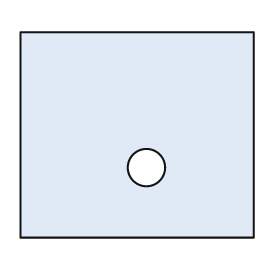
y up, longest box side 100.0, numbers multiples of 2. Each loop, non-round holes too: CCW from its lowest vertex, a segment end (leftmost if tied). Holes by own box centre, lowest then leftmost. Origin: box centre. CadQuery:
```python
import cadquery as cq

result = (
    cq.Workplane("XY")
    .moveTo(-50.0, -44.0)
    .lineTo(50.0, -44.0)
    .lineTo(50.0, 44.0)
    .lineTo(-50.0, 44.0)
    .close()
    .moveTo(4.0, -14.0)
    .circle(8.0)
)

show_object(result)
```